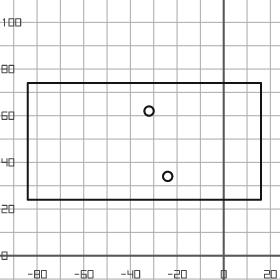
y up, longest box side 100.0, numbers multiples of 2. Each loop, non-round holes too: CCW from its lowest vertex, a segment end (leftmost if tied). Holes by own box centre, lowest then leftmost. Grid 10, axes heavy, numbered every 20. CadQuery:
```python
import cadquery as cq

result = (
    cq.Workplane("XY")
    .moveTo(-84.0, 24.0)
    .lineTo(16.0, 24.0)
    .lineTo(16.0, 74.0)
    .lineTo(-84.0, 74.0)
    .close()
    .moveTo(-24.0, 34.0)
    .circle(2.0)
    .moveTo(-32.0, 62.0)
    .circle(2.0)
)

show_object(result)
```